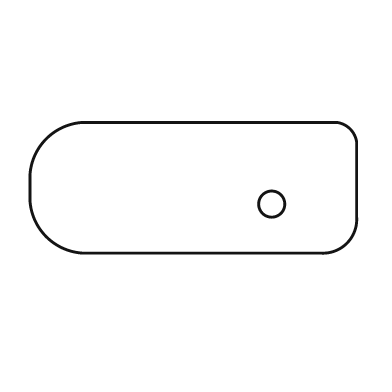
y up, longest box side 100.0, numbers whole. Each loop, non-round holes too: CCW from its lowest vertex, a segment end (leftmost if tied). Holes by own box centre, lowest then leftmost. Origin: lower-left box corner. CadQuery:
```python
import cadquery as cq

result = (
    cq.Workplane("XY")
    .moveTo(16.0, 0.0)
    .lineTo(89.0, 0.0)
    .threePointArc((97.0, 3.0), (100.0, 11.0))
    .lineTo(100.0, 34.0)
    .threePointArc((98.0, 38.0), (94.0, 40.0))
    .lineTo(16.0, 40.0)
    .threePointArc((5.0, 35.0), (0.0, 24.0))
    .lineTo(0.0, 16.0)
    .threePointArc((5.0, 5.0), (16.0, 0.0))
    .close()
    .moveTo(74.0, 15.0)
    .circle(4.0)
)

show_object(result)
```